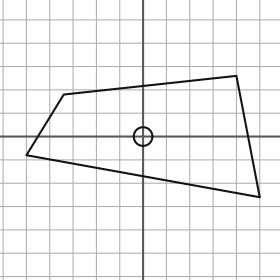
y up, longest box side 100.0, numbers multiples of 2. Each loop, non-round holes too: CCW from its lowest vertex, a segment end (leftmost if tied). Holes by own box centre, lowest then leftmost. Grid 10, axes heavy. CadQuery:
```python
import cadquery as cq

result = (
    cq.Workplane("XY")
    .moveTo(50.0, -26.0)
    .lineTo(40.0, 26.0)
    .lineTo(-34.0, 18.0)
    .lineTo(-50.0, -8.0)
    .close()
    .moveTo(0.0, 0.0)
    .circle(4.0)
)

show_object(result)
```